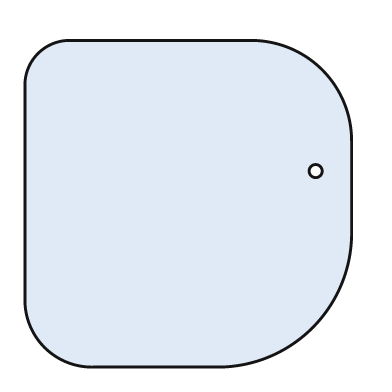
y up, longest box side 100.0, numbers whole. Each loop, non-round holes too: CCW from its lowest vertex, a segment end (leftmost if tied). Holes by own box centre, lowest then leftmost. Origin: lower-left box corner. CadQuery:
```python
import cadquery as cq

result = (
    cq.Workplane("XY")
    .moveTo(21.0, 0.0)
    .lineTo(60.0, 0.0)
    .threePointArc((88.0, 12.0), (100.0, 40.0))
    .lineTo(100.0, 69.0)
    .threePointArc((91.0, 91.0), (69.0, 100.0))
    .lineTo(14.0, 100.0)
    .threePointArc((4.0, 96.0), (0.0, 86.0))
    .lineTo(0.0, 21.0)
    .threePointArc((6.0, 6.0), (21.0, 0.0))
    .close()
    .moveTo(89.0, 60.0)
    .circle(2.0)
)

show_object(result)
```